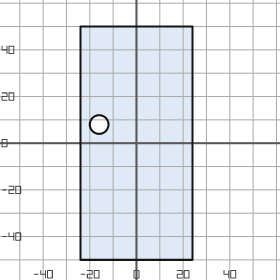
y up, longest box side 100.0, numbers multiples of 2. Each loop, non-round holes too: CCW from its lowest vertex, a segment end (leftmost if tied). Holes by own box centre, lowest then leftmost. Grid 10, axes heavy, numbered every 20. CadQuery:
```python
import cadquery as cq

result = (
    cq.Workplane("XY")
    .moveTo(-24.0, -50.0)
    .lineTo(24.0, -50.0)
    .lineTo(24.0, 50.0)
    .lineTo(-24.0, 50.0)
    .close()
    .moveTo(-16.0, 8.0)
    .circle(4.0)
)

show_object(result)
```